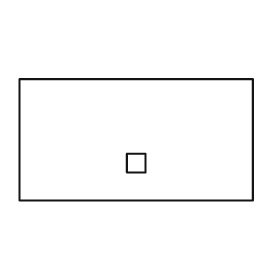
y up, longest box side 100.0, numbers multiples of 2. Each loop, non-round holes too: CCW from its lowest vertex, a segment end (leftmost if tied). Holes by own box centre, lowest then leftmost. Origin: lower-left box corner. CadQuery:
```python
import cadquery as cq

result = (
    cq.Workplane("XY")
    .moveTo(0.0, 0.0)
    .lineTo(100.0, 0.0)
    .lineTo(100.0, 52.0)
    .lineTo(0.0, 52.0)
    .close()
    .moveTo(46.0, 12.0)
    .lineTo(54.0, 12.0)
    .lineTo(54.0, 20.0)
    .lineTo(46.0, 20.0)
    .close()
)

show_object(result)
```